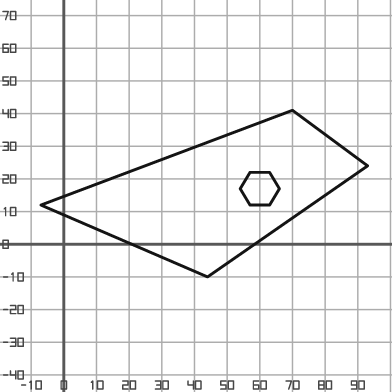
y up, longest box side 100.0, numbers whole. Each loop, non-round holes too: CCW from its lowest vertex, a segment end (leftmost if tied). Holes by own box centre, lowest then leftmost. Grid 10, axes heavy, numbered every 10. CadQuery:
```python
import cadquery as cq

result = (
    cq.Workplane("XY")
    .moveTo(44.0, -10.0)
    .lineTo(93.0, 24.0)
    .lineTo(70.0, 41.0)
    .lineTo(-7.0, 12.0)
    .close()
    .moveTo(57.0, 12.0)
    .lineTo(63.0, 12.0)
    .lineTo(66.0, 17.0)
    .lineTo(63.0, 22.0)
    .lineTo(57.0, 22.0)
    .lineTo(54.0, 17.0)
    .close()
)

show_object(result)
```